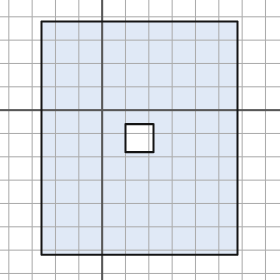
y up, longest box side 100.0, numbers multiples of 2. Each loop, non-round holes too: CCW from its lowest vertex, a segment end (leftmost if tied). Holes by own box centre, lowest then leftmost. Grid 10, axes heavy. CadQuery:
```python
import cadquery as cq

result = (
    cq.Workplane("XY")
    .moveTo(-26.0, -62.0)
    .lineTo(58.0, -62.0)
    .lineTo(58.0, 38.0)
    .lineTo(-26.0, 38.0)
    .close()
    .moveTo(10.0, -18.0)
    .lineTo(22.0, -18.0)
    .lineTo(22.0, -6.0)
    .lineTo(10.0, -6.0)
    .close()
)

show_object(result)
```